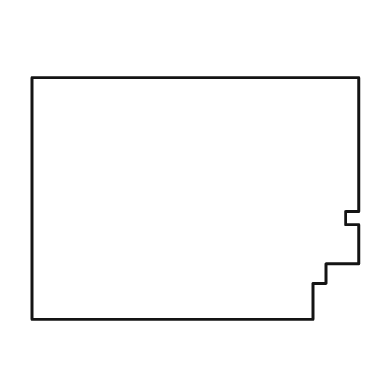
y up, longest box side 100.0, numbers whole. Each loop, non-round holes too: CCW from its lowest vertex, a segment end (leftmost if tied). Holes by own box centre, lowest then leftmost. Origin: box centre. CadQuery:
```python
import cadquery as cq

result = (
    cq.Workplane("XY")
    .moveTo(-50.0, -37.0)
    .lineTo(36.0, -37.0)
    .lineTo(36.0, -26.0)
    .lineTo(40.0, -26.0)
    .lineTo(40.0, -20.0)
    .lineTo(50.0, -20.0)
    .lineTo(50.0, -8.0)
    .lineTo(46.0, -8.0)
    .lineTo(46.0, -4.0)
    .lineTo(50.0, -4.0)
    .lineTo(50.0, 37.0)
    .lineTo(-50.0, 37.0)
    .close()
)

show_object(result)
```